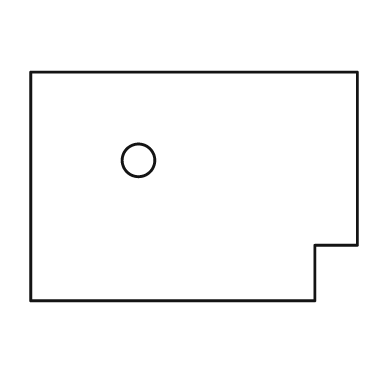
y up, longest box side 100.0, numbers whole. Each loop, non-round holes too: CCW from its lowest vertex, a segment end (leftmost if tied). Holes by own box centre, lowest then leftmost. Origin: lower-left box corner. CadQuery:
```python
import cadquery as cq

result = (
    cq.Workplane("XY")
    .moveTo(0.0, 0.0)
    .lineTo(87.0, 0.0)
    .lineTo(87.0, 17.0)
    .lineTo(100.0, 17.0)
    .lineTo(100.0, 70.0)
    .lineTo(0.0, 70.0)
    .close()
    .moveTo(33.0, 43.0)
    .circle(5.0)
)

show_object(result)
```